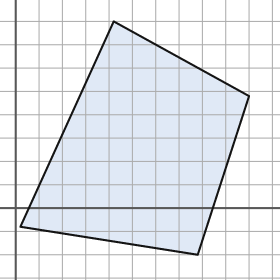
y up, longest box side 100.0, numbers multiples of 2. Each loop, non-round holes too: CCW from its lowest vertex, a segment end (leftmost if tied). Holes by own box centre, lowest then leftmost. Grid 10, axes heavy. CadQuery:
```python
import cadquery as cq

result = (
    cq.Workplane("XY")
    .moveTo(78.0, -20.0)
    .lineTo(100.0, 48.0)
    .lineTo(42.0, 80.0)
    .lineTo(2.0, -8.0)
    .close()
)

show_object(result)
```